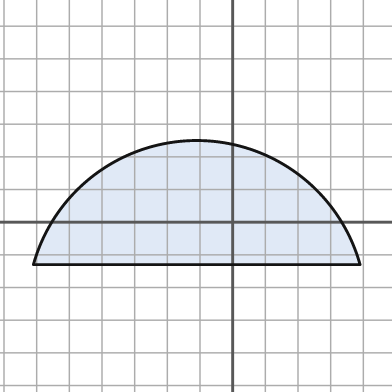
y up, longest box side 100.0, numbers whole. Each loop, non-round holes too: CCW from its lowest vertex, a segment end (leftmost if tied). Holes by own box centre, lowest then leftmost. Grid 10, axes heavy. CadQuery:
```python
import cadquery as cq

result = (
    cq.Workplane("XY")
    .moveTo(-61.0, -13.0)
    .lineTo(39.0, -13.0)
    .threePointArc((-11.0, 25.0), (-61.0, -13.0))
    .close()
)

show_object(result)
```